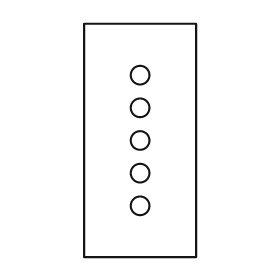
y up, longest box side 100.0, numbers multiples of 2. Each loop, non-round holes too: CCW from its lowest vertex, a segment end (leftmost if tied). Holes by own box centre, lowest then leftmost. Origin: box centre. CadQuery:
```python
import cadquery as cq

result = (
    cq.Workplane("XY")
    .moveTo(-24.0, -50.0)
    .lineTo(24.0, -50.0)
    .lineTo(24.0, 50.0)
    .lineTo(-24.0, 50.0)
    .close()
    .moveTo(0.0, -28.0)
    .circle(4.0)
    .moveTo(0.0, -14.0)
    .circle(4.0)
    .moveTo(0.0, 0.0)
    .circle(4.0)
    .moveTo(0.0, 14.0)
    .circle(4.0)
    .moveTo(0.0, 28.0)
    .circle(4.0)
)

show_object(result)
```